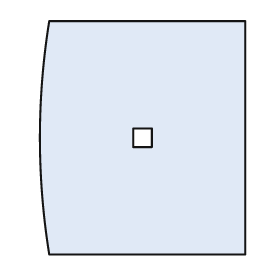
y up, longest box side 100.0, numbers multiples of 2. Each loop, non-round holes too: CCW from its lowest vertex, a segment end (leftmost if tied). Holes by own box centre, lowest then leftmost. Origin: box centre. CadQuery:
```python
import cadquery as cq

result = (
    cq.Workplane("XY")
    .moveTo(-40.0, -50.0)
    .lineTo(44.0, -50.0)
    .lineTo(44.0, 50.0)
    .lineTo(-40.0, 50.0)
    .threePointArc((-44.0, 0.0), (-40.0, -50.0))
    .close()
    .moveTo(-4.0, -4.0)
    .lineTo(4.0, -4.0)
    .lineTo(4.0, 4.0)
    .lineTo(-4.0, 4.0)
    .close()
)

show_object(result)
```